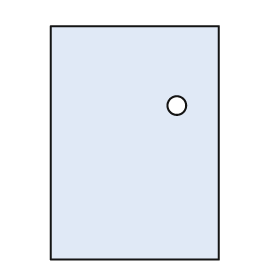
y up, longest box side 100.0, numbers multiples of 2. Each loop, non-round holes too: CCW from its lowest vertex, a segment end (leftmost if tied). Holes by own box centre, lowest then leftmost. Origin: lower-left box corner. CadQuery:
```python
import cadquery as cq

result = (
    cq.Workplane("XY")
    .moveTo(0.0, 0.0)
    .lineTo(72.0, 0.0)
    .lineTo(72.0, 100.0)
    .lineTo(0.0, 100.0)
    .close()
    .moveTo(54.0, 66.0)
    .circle(4.0)
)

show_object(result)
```